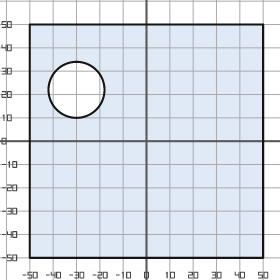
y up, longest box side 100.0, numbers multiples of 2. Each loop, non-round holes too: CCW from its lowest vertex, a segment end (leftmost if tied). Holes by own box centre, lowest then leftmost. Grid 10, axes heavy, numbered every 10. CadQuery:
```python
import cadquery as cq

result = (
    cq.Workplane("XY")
    .moveTo(-50.0, -50.0)
    .lineTo(50.0, -50.0)
    .lineTo(50.0, 50.0)
    .lineTo(-50.0, 50.0)
    .close()
    .moveTo(-30.0, 22.0)
    .circle(12.0)
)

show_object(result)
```